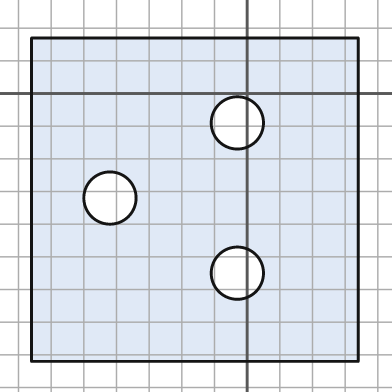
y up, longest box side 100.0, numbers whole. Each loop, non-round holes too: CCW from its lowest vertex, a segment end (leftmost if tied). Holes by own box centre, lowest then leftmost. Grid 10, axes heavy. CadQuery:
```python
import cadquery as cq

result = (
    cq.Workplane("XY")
    .moveTo(-66.0, -82.0)
    .lineTo(34.0, -82.0)
    .lineTo(34.0, 17.0)
    .lineTo(-66.0, 17.0)
    .close()
    .moveTo(-3.0, -55.0)
    .circle(8.0)
    .moveTo(-42.0, -32.0)
    .circle(8.0)
    .moveTo(-3.0, -9.0)
    .circle(8.0)
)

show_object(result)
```